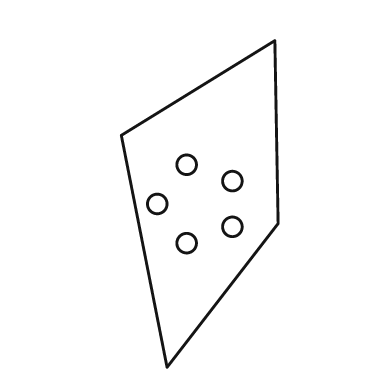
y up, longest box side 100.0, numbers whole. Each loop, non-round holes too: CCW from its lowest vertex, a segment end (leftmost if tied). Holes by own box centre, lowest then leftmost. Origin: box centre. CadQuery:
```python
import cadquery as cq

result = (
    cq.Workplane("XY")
    .moveTo(-10.0, -50.0)
    .lineTo(24.0, -6.0)
    .lineTo(23.0, 50.0)
    .lineTo(-24.0, 21.0)
    .close()
    .moveTo(-4.0, -12.0)
    .circle(3.0)
    .moveTo(10.0, -7.0)
    .circle(3.0)
    .moveTo(-13.0, 0.0)
    .circle(3.0)
    .moveTo(10.0, 7.0)
    .circle(3.0)
    .moveTo(-4.0, 12.0)
    .circle(3.0)
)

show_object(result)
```